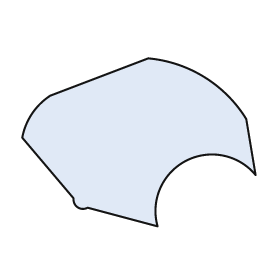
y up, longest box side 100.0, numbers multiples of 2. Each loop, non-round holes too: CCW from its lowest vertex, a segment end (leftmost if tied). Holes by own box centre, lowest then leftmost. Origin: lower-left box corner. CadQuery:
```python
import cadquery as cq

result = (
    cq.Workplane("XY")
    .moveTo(58.0, 0.0)
    .threePointArc((70.0, 28.0), (100.0, 22.0))
    .lineTo(96.0, 46.0)
    .threePointArc((78.0, 64.0), (54.0, 72.0))
    .lineTo(12.0, 56.0)
    .threePointArc((4.0, 48.0), (0.0, 38.0))
    .lineTo(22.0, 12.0)
    .threePointArc((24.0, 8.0), (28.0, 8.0))
    .close()
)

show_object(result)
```